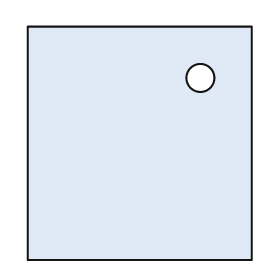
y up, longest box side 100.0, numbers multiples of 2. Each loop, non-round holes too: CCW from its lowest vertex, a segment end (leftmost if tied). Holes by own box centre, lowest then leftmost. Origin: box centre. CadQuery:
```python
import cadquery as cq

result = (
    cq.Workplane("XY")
    .moveTo(-48.0, -50.0)
    .lineTo(48.0, -50.0)
    .lineTo(48.0, 50.0)
    .lineTo(-48.0, 50.0)
    .close()
    .moveTo(26.0, 28.0)
    .circle(6.0)
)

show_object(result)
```